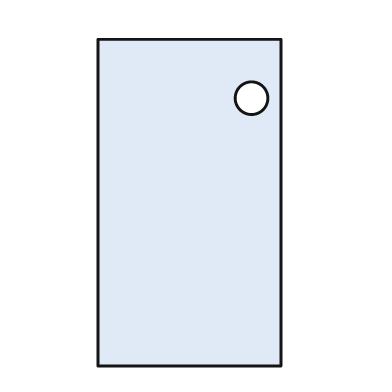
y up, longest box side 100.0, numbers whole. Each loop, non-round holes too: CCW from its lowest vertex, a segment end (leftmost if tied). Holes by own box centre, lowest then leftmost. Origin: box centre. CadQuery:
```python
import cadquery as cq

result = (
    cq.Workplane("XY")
    .moveTo(-28.0, -50.0)
    .lineTo(28.0, -50.0)
    .lineTo(28.0, 50.0)
    .lineTo(-28.0, 50.0)
    .close()
    .moveTo(19.0, 32.0)
    .circle(5.0)
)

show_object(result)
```